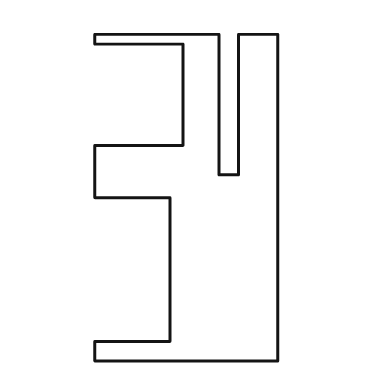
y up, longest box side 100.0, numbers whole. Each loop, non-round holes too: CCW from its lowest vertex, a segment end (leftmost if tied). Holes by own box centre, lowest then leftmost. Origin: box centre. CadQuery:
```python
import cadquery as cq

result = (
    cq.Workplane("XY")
    .moveTo(-28.0, -50.0)
    .lineTo(28.0, -50.0)
    .lineTo(28.0, 50.0)
    .lineTo(16.0, 50.0)
    .lineTo(16.0, 7.0)
    .lineTo(10.0, 7.0)
    .lineTo(10.0, 50.0)
    .lineTo(-28.0, 50.0)
    .lineTo(-28.0, 47.0)
    .lineTo(-1.0, 47.0)
    .lineTo(-1.0, 16.0)
    .lineTo(-28.0, 16.0)
    .lineTo(-28.0, 0.0)
    .lineTo(-5.0, 0.0)
    .lineTo(-5.0, -44.0)
    .lineTo(-28.0, -44.0)
    .close()
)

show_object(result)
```